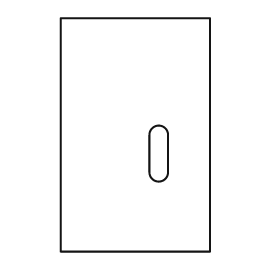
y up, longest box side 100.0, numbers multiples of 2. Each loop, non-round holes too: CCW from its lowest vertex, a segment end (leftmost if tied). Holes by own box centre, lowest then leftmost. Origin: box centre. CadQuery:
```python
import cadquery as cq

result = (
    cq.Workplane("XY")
    .moveTo(-32.0, -50.0)
    .lineTo(32.0, -50.0)
    .lineTo(32.0, 50.0)
    .lineTo(-32.0, 50.0)
    .close()
    .moveTo(6.0, -16.0)
    .threePointArc((10.0, -20.0), (14.0, -16.0))
    .lineTo(14.0, 0.0)
    .threePointArc((10.0, 4.0), (6.0, 0.0))
    .close()
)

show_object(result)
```